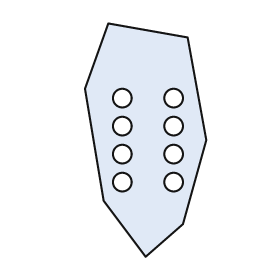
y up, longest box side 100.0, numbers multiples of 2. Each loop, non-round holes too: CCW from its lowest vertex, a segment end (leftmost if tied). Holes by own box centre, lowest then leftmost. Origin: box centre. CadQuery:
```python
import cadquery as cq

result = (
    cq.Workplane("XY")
    .moveTo(0.0, -50.0)
    .lineTo(16.0, -36.0)
    .lineTo(26.0, 0.0)
    .lineTo(18.0, 44.0)
    .lineTo(-16.0, 50.0)
    .lineTo(-26.0, 22.0)
    .lineTo(-18.0, -26.0)
    .close()
    .moveTo(-10.0, -18.0)
    .circle(4.0)
    .moveTo(12.0, -18.0)
    .circle(4.0)
    .moveTo(-10.0, -6.0)
    .circle(4.0)
    .moveTo(12.0, -6.0)
    .circle(4.0)
    .moveTo(-10.0, 6.0)
    .circle(4.0)
    .moveTo(12.0, 6.0)
    .circle(4.0)
    .moveTo(-10.0, 18.0)
    .circle(4.0)
    .moveTo(12.0, 18.0)
    .circle(4.0)
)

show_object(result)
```